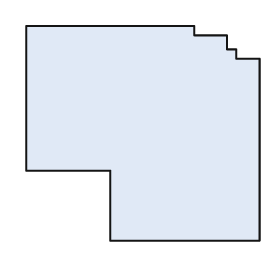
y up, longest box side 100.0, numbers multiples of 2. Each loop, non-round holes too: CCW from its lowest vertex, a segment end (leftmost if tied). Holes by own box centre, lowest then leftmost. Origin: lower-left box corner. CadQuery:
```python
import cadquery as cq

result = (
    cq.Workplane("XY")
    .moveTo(36.0, 0.0)
    .lineTo(100.0, 0.0)
    .lineTo(100.0, 78.0)
    .lineTo(90.0, 78.0)
    .lineTo(90.0, 82.0)
    .lineTo(86.0, 82.0)
    .lineTo(86.0, 88.0)
    .lineTo(72.0, 88.0)
    .lineTo(72.0, 92.0)
    .lineTo(0.0, 92.0)
    .lineTo(0.0, 30.0)
    .lineTo(36.0, 30.0)
    .close()
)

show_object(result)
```